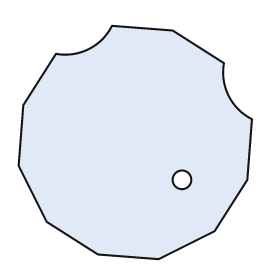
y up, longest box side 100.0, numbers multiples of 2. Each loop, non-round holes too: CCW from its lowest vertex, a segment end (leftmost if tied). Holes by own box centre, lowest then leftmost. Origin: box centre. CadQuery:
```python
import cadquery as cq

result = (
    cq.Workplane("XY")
    .moveTo(10.0, -50.0)
    .lineTo(34.0, -38.0)
    .lineTo(48.0, -16.0)
    .lineTo(50.0, 10.0)
    .threePointArc((40.0, 20.0), (38.0, 34.0))
    .lineTo(16.0, 48.0)
    .lineTo(-10.0, 50.0)
    .threePointArc((-20.0, 40.0), (-34.0, 38.0))
    .lineTo(-48.0, 16.0)
    .lineTo(-50.0, -10.0)
    .lineTo(-38.0, -34.0)
    .lineTo(-16.0, -48.0)
    .close()
    .moveTo(20.0, -16.0)
    .circle(4.0)
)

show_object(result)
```